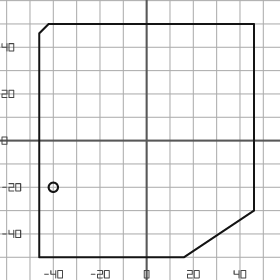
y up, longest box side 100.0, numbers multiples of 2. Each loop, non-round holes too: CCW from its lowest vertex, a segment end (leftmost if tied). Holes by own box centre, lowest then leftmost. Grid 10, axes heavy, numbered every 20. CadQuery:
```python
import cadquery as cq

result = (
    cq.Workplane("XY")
    .moveTo(-46.0, -50.0)
    .lineTo(16.0, -50.0)
    .lineTo(46.0, -30.0)
    .lineTo(46.0, 50.0)
    .lineTo(-42.0, 50.0)
    .lineTo(-46.0, 46.0)
    .close()
    .moveTo(-40.0, -20.0)
    .circle(2.0)
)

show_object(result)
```